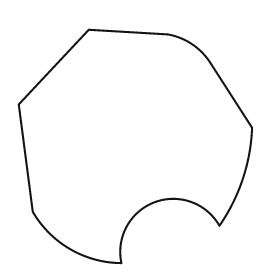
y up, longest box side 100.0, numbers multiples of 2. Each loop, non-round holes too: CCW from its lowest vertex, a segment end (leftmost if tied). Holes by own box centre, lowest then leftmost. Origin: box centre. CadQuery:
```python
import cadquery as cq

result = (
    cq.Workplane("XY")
    .moveTo(-6.0, -50.0)
    .threePointArc((8.0, -24.0), (36.0, -34.0))
    .threePointArc((46.0, -14.0), (50.0, 8.0))
    .lineTo(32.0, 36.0)
    .threePointArc((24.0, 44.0), (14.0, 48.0))
    .lineTo(-20.0, 50.0)
    .lineTo(-50.0, 18.0)
    .lineTo(-44.0, -28.0)
    .threePointArc((-28.0, -44.0), (-6.0, -50.0))
    .close()
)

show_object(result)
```